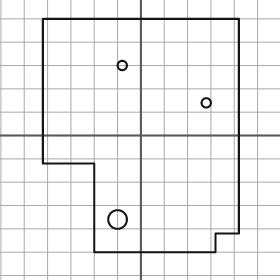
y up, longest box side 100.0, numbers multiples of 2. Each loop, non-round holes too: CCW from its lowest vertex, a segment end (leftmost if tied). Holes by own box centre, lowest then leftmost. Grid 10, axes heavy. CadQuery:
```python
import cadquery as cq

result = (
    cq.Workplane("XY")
    .moveTo(-20.0, -50.0)
    .lineTo(32.0, -50.0)
    .lineTo(32.0, -42.0)
    .lineTo(42.0, -42.0)
    .lineTo(42.0, 50.0)
    .lineTo(-42.0, 50.0)
    .lineTo(-42.0, -12.0)
    .lineTo(-20.0, -12.0)
    .close()
    .moveTo(-10.0, -36.0)
    .circle(4.0)
    .moveTo(28.0, 14.0)
    .circle(2.0)
    .moveTo(-8.0, 30.0)
    .circle(2.0)
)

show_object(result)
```